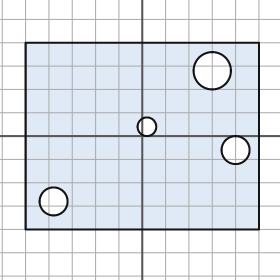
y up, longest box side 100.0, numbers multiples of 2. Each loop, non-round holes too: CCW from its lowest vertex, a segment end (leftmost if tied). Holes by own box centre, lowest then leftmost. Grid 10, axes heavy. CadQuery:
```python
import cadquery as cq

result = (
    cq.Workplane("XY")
    .moveTo(-50.0, -40.0)
    .lineTo(50.0, -40.0)
    .lineTo(50.0, 40.0)
    .lineTo(-50.0, 40.0)
    .close()
    .moveTo(-38.0, -28.0)
    .circle(6.0)
    .moveTo(40.0, -6.0)
    .circle(6.0)
    .moveTo(2.0, 4.0)
    .circle(4.0)
    .moveTo(30.0, 28.0)
    .circle(8.0)
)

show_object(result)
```